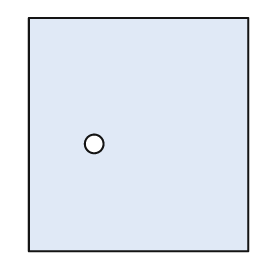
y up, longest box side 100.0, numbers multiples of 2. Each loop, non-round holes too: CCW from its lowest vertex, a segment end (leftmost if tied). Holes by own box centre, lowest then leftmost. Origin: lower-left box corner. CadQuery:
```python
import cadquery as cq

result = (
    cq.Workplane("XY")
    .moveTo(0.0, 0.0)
    .lineTo(94.0, 0.0)
    .lineTo(94.0, 100.0)
    .lineTo(0.0, 100.0)
    .close()
    .moveTo(28.0, 46.0)
    .circle(4.0)
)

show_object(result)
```